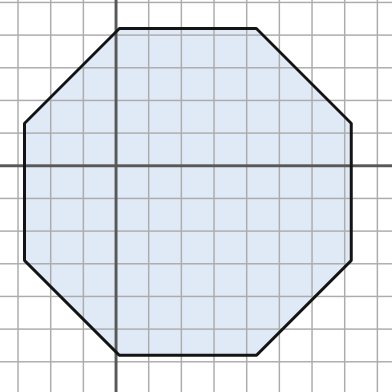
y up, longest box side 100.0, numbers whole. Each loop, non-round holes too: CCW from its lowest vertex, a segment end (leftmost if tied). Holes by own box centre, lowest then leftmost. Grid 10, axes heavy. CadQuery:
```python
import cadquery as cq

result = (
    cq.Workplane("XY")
    .moveTo(1.0, -58.0)
    .lineTo(43.0, -58.0)
    .lineTo(72.0, -29.0)
    .lineTo(72.0, 13.0)
    .lineTo(43.0, 42.0)
    .lineTo(1.0, 42.0)
    .lineTo(-28.0, 13.0)
    .lineTo(-28.0, -29.0)
    .close()
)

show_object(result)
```